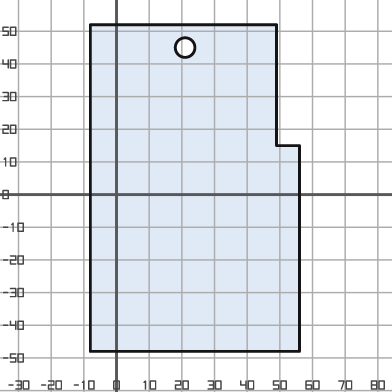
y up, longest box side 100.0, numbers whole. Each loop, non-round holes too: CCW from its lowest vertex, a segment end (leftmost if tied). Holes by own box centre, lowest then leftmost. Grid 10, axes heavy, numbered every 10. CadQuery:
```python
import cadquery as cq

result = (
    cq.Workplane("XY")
    .moveTo(-8.0, -48.0)
    .lineTo(56.0, -48.0)
    .lineTo(56.0, 15.0)
    .lineTo(49.0, 15.0)
    .lineTo(49.0, 52.0)
    .lineTo(-8.0, 52.0)
    .close()
    .moveTo(21.0, 45.0)
    .circle(3.0)
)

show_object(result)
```